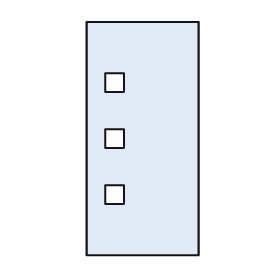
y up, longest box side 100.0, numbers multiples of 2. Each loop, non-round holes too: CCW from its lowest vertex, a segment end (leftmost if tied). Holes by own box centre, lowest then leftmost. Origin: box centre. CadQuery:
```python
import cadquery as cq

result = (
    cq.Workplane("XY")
    .moveTo(-24.0, -50.0)
    .lineTo(24.0, -50.0)
    .lineTo(24.0, 50.0)
    .lineTo(-24.0, 50.0)
    .close()
    .moveTo(-16.0, -28.0)
    .lineTo(-8.0, -28.0)
    .lineTo(-8.0, -20.0)
    .lineTo(-16.0, -20.0)
    .close()
    .moveTo(-16.0, -4.0)
    .lineTo(-8.0, -4.0)
    .lineTo(-8.0, 4.0)
    .lineTo(-16.0, 4.0)
    .close()
    .moveTo(-16.0, 20.0)
    .lineTo(-8.0, 20.0)
    .lineTo(-8.0, 28.0)
    .lineTo(-16.0, 28.0)
    .close()
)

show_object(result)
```